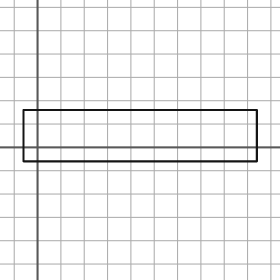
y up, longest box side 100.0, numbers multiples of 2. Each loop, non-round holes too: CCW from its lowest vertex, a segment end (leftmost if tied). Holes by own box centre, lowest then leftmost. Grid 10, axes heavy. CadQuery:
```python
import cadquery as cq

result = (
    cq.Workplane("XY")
    .moveTo(-6.0, -6.0)
    .lineTo(94.0, -6.0)
    .lineTo(94.0, 16.0)
    .lineTo(-6.0, 16.0)
    .close()
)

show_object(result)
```